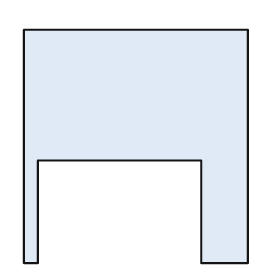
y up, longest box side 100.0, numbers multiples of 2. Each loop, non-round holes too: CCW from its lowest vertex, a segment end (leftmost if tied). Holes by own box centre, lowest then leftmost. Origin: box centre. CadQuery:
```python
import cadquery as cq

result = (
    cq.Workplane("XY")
    .moveTo(-48.0, -50.0)
    .lineTo(-42.0, -50.0)
    .lineTo(-42.0, -6.0)
    .lineTo(28.0, -6.0)
    .lineTo(28.0, -50.0)
    .lineTo(48.0, -50.0)
    .lineTo(48.0, 50.0)
    .lineTo(-48.0, 50.0)
    .close()
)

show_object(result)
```